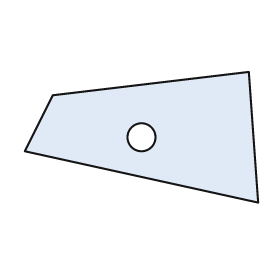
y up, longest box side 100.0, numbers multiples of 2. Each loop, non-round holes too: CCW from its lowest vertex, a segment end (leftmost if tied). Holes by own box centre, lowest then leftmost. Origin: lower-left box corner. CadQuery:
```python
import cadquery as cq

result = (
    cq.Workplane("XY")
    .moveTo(100.0, 0.0)
    .lineTo(96.0, 56.0)
    .lineTo(12.0, 46.0)
    .lineTo(0.0, 22.0)
    .close()
    .moveTo(50.0, 28.0)
    .circle(6.0)
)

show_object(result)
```